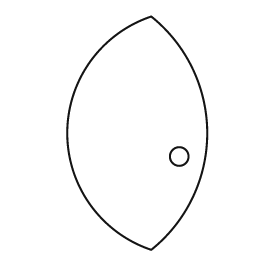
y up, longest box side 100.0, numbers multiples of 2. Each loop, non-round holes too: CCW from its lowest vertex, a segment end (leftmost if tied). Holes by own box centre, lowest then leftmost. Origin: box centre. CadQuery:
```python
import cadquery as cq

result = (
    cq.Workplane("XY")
    .moveTo(6.0, -50.0)
    .threePointArc((30.0, 0.0), (6.0, 50.0))
    .threePointArc((-30.0, 0.0), (6.0, -50.0))
    .close()
    .moveTo(18.0, -10.0)
    .circle(4.0)
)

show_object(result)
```